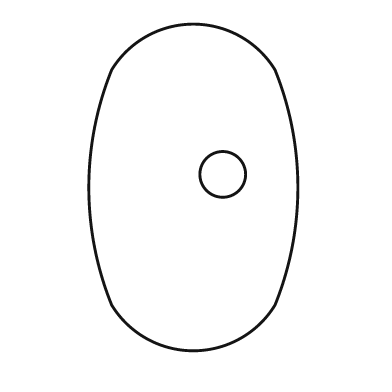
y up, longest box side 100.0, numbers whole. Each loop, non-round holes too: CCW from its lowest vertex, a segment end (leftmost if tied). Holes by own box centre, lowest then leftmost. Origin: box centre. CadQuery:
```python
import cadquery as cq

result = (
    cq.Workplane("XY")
    .moveTo(-25.0, -36.0)
    .threePointArc((0.0, -50.0), (25.0, -36.0))
    .threePointArc((32.0, 0.0), (25.0, 36.0))
    .threePointArc((0.0, 50.0), (-25.0, 36.0))
    .threePointArc((-32.0, 0.0), (-25.0, -36.0))
    .close()
    .moveTo(9.0, 4.0)
    .circle(7.0)
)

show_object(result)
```